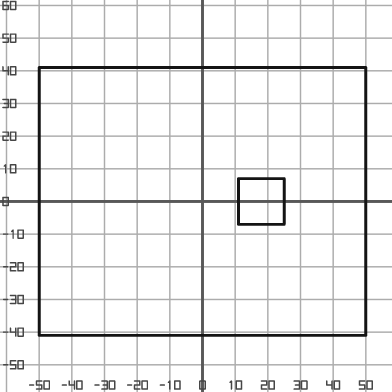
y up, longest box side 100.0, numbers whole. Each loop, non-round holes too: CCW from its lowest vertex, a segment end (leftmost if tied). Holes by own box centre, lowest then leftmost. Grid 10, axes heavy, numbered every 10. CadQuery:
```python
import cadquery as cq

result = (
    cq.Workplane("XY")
    .moveTo(-50.0, -41.0)
    .lineTo(50.0, -41.0)
    .lineTo(50.0, 41.0)
    .lineTo(-50.0, 41.0)
    .close()
    .moveTo(11.0, -7.0)
    .lineTo(25.0, -7.0)
    .lineTo(25.0, 7.0)
    .lineTo(11.0, 7.0)
    .close()
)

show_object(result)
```